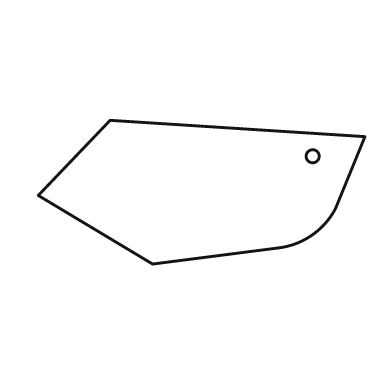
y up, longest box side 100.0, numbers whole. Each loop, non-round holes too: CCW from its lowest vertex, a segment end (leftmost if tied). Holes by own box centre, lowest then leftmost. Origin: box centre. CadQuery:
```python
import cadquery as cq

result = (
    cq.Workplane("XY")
    .moveTo(-15.0, -22.0)
    .lineTo(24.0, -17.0)
    .threePointArc((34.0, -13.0), (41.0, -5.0))
    .lineTo(50.0, 17.0)
    .lineTo(-28.0, 22.0)
    .lineTo(-50.0, -1.0)
    .close()
    .moveTo(34.0, 11.0)
    .circle(2.0)
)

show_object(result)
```